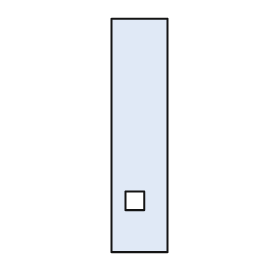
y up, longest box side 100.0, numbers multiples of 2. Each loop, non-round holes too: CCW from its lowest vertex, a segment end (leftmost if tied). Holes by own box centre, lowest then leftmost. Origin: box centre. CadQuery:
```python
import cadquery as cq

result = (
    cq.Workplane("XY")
    .moveTo(-12.0, -50.0)
    .lineTo(12.0, -50.0)
    .lineTo(12.0, 50.0)
    .lineTo(-12.0, 50.0)
    .close()
    .moveTo(-6.0, -32.0)
    .lineTo(2.0, -32.0)
    .lineTo(2.0, -24.0)
    .lineTo(-6.0, -24.0)
    .close()
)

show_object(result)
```